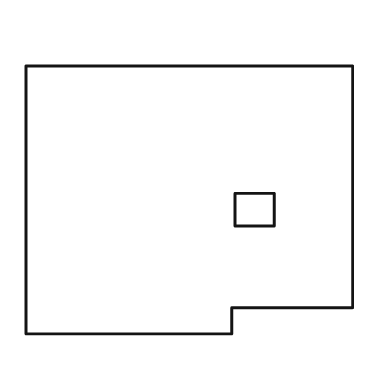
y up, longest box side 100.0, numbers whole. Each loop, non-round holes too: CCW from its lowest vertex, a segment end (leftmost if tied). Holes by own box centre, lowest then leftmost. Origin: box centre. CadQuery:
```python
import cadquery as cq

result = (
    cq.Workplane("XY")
    .moveTo(-50.0, -41.0)
    .lineTo(13.0, -41.0)
    .lineTo(13.0, -33.0)
    .lineTo(50.0, -33.0)
    .lineTo(50.0, 41.0)
    .lineTo(-50.0, 41.0)
    .close()
    .moveTo(14.0, -8.0)
    .lineTo(26.0, -8.0)
    .lineTo(26.0, 2.0)
    .lineTo(14.0, 2.0)
    .close()
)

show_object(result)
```